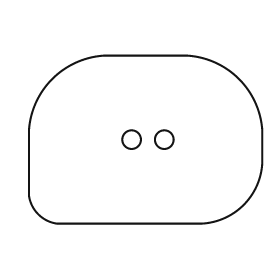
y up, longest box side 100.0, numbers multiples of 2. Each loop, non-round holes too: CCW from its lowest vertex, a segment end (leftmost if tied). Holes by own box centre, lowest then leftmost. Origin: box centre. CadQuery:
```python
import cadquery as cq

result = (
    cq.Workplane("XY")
    .moveTo(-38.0, -36.0)
    .lineTo(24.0, -36.0)
    .threePointArc((42.0, -28.0), (50.0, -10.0))
    .lineTo(50.0, 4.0)
    .threePointArc((40.0, 26.0), (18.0, 36.0))
    .lineTo(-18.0, 36.0)
    .threePointArc((-40.0, 26.0), (-50.0, 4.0))
    .lineTo(-50.0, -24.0)
    .threePointArc((-46.0, -32.0), (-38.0, -36.0))
    .close()
    .moveTo(-6.0, 0.0)
    .circle(4.0)
    .moveTo(8.0, 0.0)
    .circle(4.0)
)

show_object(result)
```